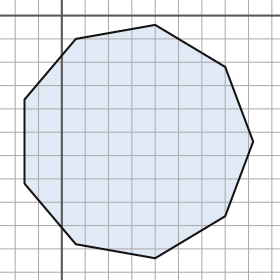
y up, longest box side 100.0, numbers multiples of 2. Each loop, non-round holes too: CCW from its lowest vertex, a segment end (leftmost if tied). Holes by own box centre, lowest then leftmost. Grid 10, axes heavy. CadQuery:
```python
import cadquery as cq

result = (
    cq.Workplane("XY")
    .moveTo(40.0, -104.0)
    .lineTo(70.0, -86.0)
    .lineTo(82.0, -54.0)
    .lineTo(70.0, -22.0)
    .lineTo(40.0, -4.0)
    .lineTo(6.0, -10.0)
    .lineTo(-16.0, -36.0)
    .lineTo(-16.0, -72.0)
    .lineTo(6.0, -98.0)
    .close()
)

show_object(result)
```